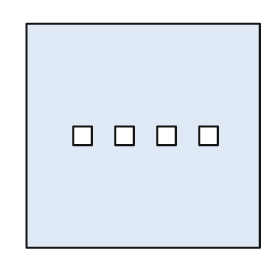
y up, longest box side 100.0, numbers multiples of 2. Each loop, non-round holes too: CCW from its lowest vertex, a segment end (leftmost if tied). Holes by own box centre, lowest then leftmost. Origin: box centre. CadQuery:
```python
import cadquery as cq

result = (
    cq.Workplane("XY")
    .moveTo(-50.0, -48.0)
    .lineTo(50.0, -48.0)
    .lineTo(50.0, 48.0)
    .lineTo(-50.0, 48.0)
    .close()
    .moveTo(-30.0, -4.0)
    .lineTo(-22.0, -4.0)
    .lineTo(-22.0, 4.0)
    .lineTo(-30.0, 4.0)
    .close()
    .moveTo(-12.0, -4.0)
    .lineTo(-4.0, -4.0)
    .lineTo(-4.0, 4.0)
    .lineTo(-12.0, 4.0)
    .close()
    .moveTo(6.0, -4.0)
    .lineTo(14.0, -4.0)
    .lineTo(14.0, 4.0)
    .lineTo(6.0, 4.0)
    .close()
    .moveTo(24.0, -4.0)
    .lineTo(32.0, -4.0)
    .lineTo(32.0, 4.0)
    .lineTo(24.0, 4.0)
    .close()
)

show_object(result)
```